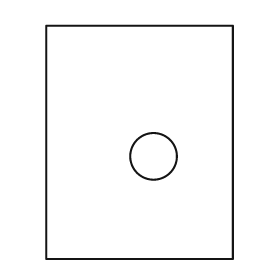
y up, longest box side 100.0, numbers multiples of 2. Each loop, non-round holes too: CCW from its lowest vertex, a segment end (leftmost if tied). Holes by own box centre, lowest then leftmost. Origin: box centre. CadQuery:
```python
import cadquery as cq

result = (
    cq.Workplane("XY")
    .moveTo(-40.0, -50.0)
    .lineTo(40.0, -50.0)
    .lineTo(40.0, 50.0)
    .lineTo(-40.0, 50.0)
    .close()
    .moveTo(6.0, -6.0)
    .circle(10.0)
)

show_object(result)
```